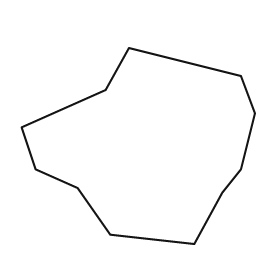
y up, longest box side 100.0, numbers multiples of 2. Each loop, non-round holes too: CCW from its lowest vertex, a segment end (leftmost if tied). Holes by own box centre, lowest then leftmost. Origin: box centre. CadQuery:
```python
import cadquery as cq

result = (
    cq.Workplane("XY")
    .moveTo(24.0, -42.0)
    .lineTo(36.0, -20.0)
    .lineTo(44.0, -10.0)
    .lineTo(50.0, 14.0)
    .lineTo(44.0, 30.0)
    .lineTo(-4.0, 42.0)
    .lineTo(-14.0, 24.0)
    .lineTo(-50.0, 8.0)
    .lineTo(-44.0, -10.0)
    .lineTo(-26.0, -18.0)
    .lineTo(-12.0, -38.0)
    .close()
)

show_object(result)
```